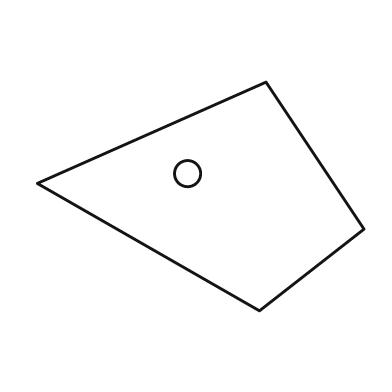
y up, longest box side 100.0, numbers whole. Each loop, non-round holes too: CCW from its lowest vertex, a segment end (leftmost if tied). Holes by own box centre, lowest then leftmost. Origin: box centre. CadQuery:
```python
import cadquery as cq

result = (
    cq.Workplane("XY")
    .moveTo(18.0, -35.0)
    .lineTo(50.0, -10.0)
    .lineTo(20.0, 35.0)
    .lineTo(-50.0, 4.0)
    .close()
    .moveTo(-4.0, 7.0)
    .circle(4.0)
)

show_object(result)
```